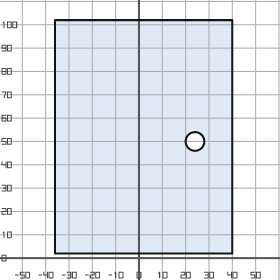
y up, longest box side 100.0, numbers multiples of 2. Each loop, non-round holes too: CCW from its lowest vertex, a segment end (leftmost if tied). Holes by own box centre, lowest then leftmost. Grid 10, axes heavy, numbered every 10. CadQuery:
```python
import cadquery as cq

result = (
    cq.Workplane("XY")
    .moveTo(-36.0, 2.0)
    .lineTo(40.0, 2.0)
    .lineTo(40.0, 102.0)
    .lineTo(-36.0, 102.0)
    .close()
    .moveTo(24.0, 50.0)
    .circle(4.0)
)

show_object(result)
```